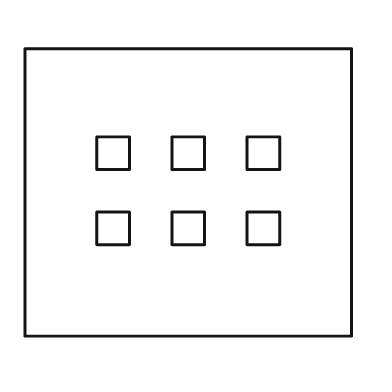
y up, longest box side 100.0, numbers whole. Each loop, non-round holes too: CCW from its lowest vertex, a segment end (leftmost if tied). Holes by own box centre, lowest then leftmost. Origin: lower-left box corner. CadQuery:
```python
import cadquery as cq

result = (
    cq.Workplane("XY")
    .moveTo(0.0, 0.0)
    .lineTo(100.0, 0.0)
    .lineTo(100.0, 88.0)
    .lineTo(0.0, 88.0)
    .close()
    .moveTo(22.0, 28.0)
    .lineTo(32.0, 28.0)
    .lineTo(32.0, 38.0)
    .lineTo(22.0, 38.0)
    .close()
    .moveTo(45.0, 28.0)
    .lineTo(55.0, 28.0)
    .lineTo(55.0, 38.0)
    .lineTo(45.0, 38.0)
    .close()
    .moveTo(68.0, 28.0)
    .lineTo(78.0, 28.0)
    .lineTo(78.0, 38.0)
    .lineTo(68.0, 38.0)
    .close()
    .moveTo(22.0, 51.0)
    .lineTo(32.0, 51.0)
    .lineTo(32.0, 61.0)
    .lineTo(22.0, 61.0)
    .close()
    .moveTo(45.0, 51.0)
    .lineTo(55.0, 51.0)
    .lineTo(55.0, 61.0)
    .lineTo(45.0, 61.0)
    .close()
    .moveTo(68.0, 51.0)
    .lineTo(78.0, 51.0)
    .lineTo(78.0, 61.0)
    .lineTo(68.0, 61.0)
    .close()
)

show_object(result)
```